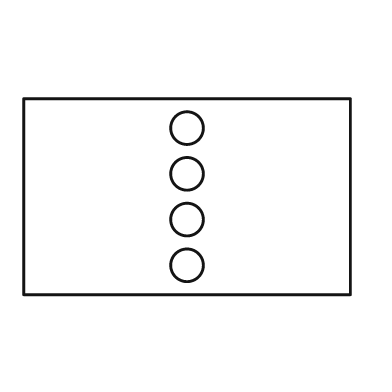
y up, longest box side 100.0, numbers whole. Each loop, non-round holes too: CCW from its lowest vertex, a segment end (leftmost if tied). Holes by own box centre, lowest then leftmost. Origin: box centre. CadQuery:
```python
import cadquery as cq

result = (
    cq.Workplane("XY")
    .moveTo(-50.0, -30.0)
    .lineTo(50.0, -30.0)
    .lineTo(50.0, 30.0)
    .lineTo(-50.0, 30.0)
    .close()
    .moveTo(0.0, -21.0)
    .circle(5.0)
    .moveTo(0.0, -7.0)
    .circle(5.0)
    .moveTo(0.0, 7.0)
    .circle(5.0)
    .moveTo(0.0, 21.0)
    .circle(5.0)
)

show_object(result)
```